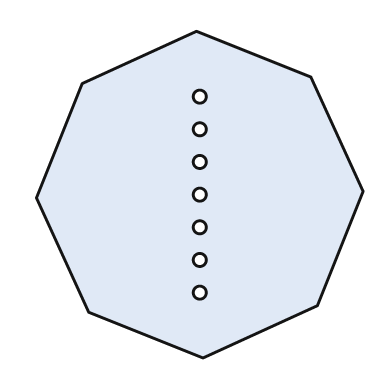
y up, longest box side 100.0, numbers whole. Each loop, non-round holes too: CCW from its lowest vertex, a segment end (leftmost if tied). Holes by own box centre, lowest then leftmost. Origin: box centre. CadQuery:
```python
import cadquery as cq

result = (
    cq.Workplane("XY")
    .moveTo(1.0, -50.0)
    .lineTo(36.0, -34.0)
    .lineTo(50.0, 1.0)
    .lineTo(34.0, 36.0)
    .lineTo(-1.0, 50.0)
    .lineTo(-36.0, 34.0)
    .lineTo(-50.0, -1.0)
    .lineTo(-34.0, -36.0)
    .close()
    .moveTo(0.0, -30.0)
    .circle(2.0)
    .moveTo(0.0, -20.0)
    .circle(2.0)
    .moveTo(0.0, -10.0)
    .circle(2.0)
    .moveTo(0.0, 0.0)
    .circle(2.0)
    .moveTo(0.0, 10.0)
    .circle(2.0)
    .moveTo(0.0, 20.0)
    .circle(2.0)
    .moveTo(0.0, 30.0)
    .circle(2.0)
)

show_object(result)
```